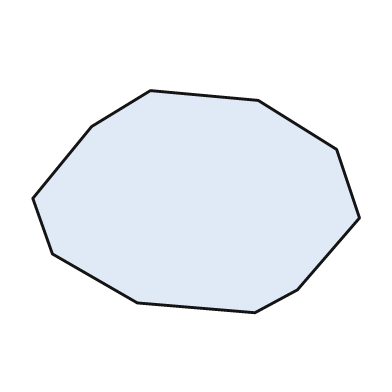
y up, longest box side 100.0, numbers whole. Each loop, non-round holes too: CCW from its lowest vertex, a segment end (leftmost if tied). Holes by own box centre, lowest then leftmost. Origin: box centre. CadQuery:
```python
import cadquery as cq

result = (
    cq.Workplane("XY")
    .moveTo(18.0, -34.0)
    .lineTo(31.0, -27.0)
    .lineTo(50.0, -5.0)
    .lineTo(43.0, 16.0)
    .lineTo(19.0, 31.0)
    .lineTo(-14.0, 34.0)
    .lineTo(-32.0, 23.0)
    .lineTo(-50.0, 1.0)
    .lineTo(-44.0, -16.0)
    .lineTo(-18.0, -31.0)
    .close()
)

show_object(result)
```